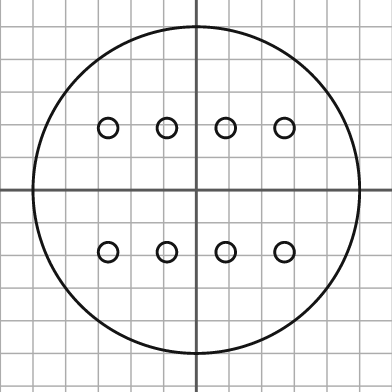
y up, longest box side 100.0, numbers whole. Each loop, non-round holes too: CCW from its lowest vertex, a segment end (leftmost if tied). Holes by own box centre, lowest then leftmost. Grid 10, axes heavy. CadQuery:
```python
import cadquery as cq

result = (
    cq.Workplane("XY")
    .moveTo(0.0, 0.0)
    .circle(50.0)
    .moveTo(-27.0, -19.0)
    .circle(3.0)
    .moveTo(-9.0, -19.0)
    .circle(3.0)
    .moveTo(9.0, -19.0)
    .circle(3.0)
    .moveTo(27.0, -19.0)
    .circle(3.0)
    .moveTo(-27.0, 19.0)
    .circle(3.0)
    .moveTo(-9.0, 19.0)
    .circle(3.0)
    .moveTo(9.0, 19.0)
    .circle(3.0)
    .moveTo(27.0, 19.0)
    .circle(3.0)
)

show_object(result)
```